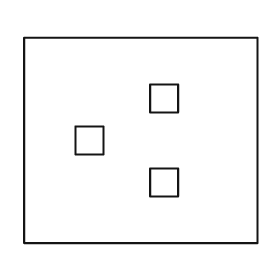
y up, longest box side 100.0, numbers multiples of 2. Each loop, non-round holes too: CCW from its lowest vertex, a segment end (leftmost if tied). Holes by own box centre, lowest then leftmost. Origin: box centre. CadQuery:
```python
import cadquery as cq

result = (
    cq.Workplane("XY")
    .moveTo(-50.0, -44.0)
    .lineTo(50.0, -44.0)
    .lineTo(50.0, 44.0)
    .lineTo(-50.0, 44.0)
    .close()
    .moveTo(4.0, -24.0)
    .lineTo(16.0, -24.0)
    .lineTo(16.0, -12.0)
    .lineTo(4.0, -12.0)
    .close()
    .moveTo(-28.0, -6.0)
    .lineTo(-16.0, -6.0)
    .lineTo(-16.0, 6.0)
    .lineTo(-28.0, 6.0)
    .close()
    .moveTo(4.0, 12.0)
    .lineTo(16.0, 12.0)
    .lineTo(16.0, 24.0)
    .lineTo(4.0, 24.0)
    .close()
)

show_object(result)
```